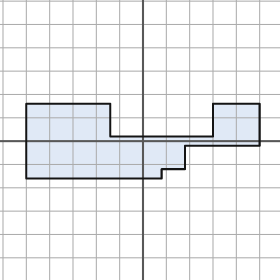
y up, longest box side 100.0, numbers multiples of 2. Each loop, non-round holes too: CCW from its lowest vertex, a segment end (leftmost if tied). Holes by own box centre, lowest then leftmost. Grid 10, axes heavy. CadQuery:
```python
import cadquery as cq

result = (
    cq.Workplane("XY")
    .moveTo(-50.0, -16.0)
    .lineTo(8.0, -16.0)
    .lineTo(8.0, -12.0)
    .lineTo(18.0, -12.0)
    .lineTo(18.0, -2.0)
    .lineTo(50.0, -2.0)
    .lineTo(50.0, 16.0)
    .lineTo(30.0, 16.0)
    .lineTo(30.0, 2.0)
    .lineTo(-14.0, 2.0)
    .lineTo(-14.0, 16.0)
    .lineTo(-50.0, 16.0)
    .close()
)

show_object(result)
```